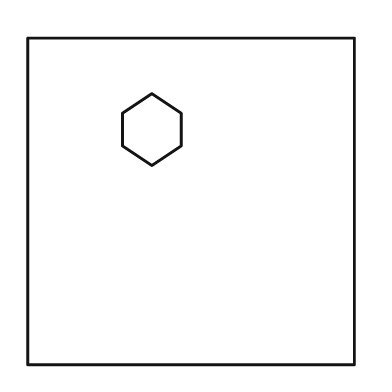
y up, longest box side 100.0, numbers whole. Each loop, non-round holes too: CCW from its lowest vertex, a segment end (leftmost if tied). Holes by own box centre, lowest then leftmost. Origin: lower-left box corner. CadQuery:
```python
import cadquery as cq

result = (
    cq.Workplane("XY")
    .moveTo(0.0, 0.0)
    .lineTo(100.0, 0.0)
    .lineTo(100.0, 100.0)
    .lineTo(0.0, 100.0)
    .close()
    .moveTo(38.0, 61.0)
    .lineTo(47.0, 67.0)
    .lineTo(47.0, 77.0)
    .lineTo(38.0, 83.0)
    .lineTo(29.0, 77.0)
    .lineTo(29.0, 67.0)
    .close()
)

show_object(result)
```